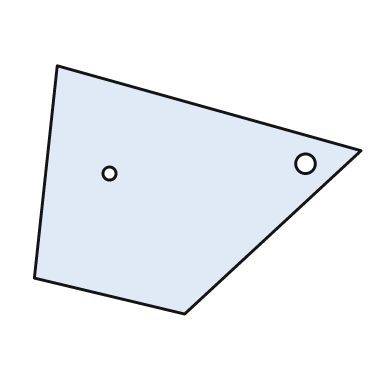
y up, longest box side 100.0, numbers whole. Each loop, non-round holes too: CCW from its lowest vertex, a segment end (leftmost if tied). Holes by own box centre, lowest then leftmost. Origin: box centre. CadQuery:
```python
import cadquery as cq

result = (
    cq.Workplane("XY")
    .moveTo(-4.0, -38.0)
    .lineTo(50.0, 12.0)
    .lineTo(-43.0, 38.0)
    .lineTo(-50.0, -27.0)
    .close()
    .moveTo(-27.0, 5.0)
    .circle(2.0)
    .moveTo(33.0, 8.0)
    .circle(3.0)
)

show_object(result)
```